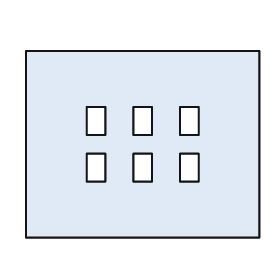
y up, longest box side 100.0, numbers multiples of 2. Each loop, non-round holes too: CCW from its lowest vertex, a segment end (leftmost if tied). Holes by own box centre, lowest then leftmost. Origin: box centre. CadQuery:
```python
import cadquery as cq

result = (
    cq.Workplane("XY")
    .moveTo(-50.0, -40.0)
    .lineTo(50.0, -40.0)
    .lineTo(50.0, 40.0)
    .lineTo(-50.0, 40.0)
    .close()
    .moveTo(-24.0, -16.0)
    .lineTo(-16.0, -16.0)
    .lineTo(-16.0, -4.0)
    .lineTo(-24.0, -4.0)
    .close()
    .moveTo(-4.0, -16.0)
    .lineTo(4.0, -16.0)
    .lineTo(4.0, -4.0)
    .lineTo(-4.0, -4.0)
    .close()
    .moveTo(16.0, -16.0)
    .lineTo(24.0, -16.0)
    .lineTo(24.0, -4.0)
    .lineTo(16.0, -4.0)
    .close()
    .moveTo(-24.0, 4.0)
    .lineTo(-16.0, 4.0)
    .lineTo(-16.0, 16.0)
    .lineTo(-24.0, 16.0)
    .close()
    .moveTo(-4.0, 4.0)
    .lineTo(4.0, 4.0)
    .lineTo(4.0, 16.0)
    .lineTo(-4.0, 16.0)
    .close()
    .moveTo(16.0, 4.0)
    .lineTo(24.0, 4.0)
    .lineTo(24.0, 16.0)
    .lineTo(16.0, 16.0)
    .close()
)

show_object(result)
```